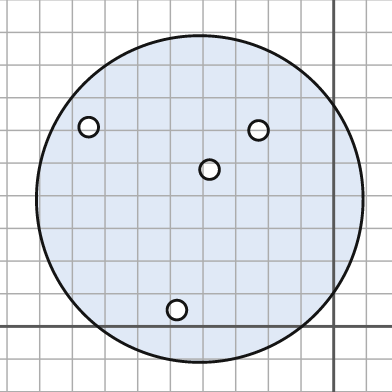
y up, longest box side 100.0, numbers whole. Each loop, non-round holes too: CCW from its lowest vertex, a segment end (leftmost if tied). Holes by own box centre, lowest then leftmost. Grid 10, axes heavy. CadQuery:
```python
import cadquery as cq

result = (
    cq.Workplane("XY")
    .moveTo(-41.0, 39.0)
    .circle(50.0)
    .moveTo(-48.0, 5.0)
    .circle(3.0)
    .moveTo(-38.0, 48.0)
    .circle(3.0)
    .moveTo(-23.0, 60.0)
    .circle(3.0)
    .moveTo(-75.0, 61.0)
    .circle(3.0)
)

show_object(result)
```